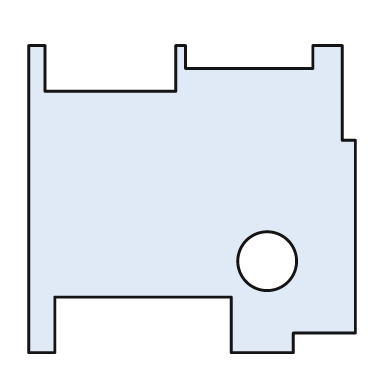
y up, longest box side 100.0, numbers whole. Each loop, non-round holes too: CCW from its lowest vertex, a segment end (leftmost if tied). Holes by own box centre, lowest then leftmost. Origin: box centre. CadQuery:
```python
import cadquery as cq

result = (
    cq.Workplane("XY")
    .moveTo(-50.0, -47.0)
    .lineTo(-42.0, -47.0)
    .lineTo(-42.0, -30.0)
    .lineTo(12.0, -30.0)
    .lineTo(12.0, -47.0)
    .lineTo(31.0, -47.0)
    .lineTo(31.0, -41.0)
    .lineTo(50.0, -41.0)
    .lineTo(50.0, 18.0)
    .lineTo(46.0, 18.0)
    .lineTo(46.0, 47.0)
    .lineTo(37.0, 47.0)
    .lineTo(37.0, 40.0)
    .lineTo(-2.0, 40.0)
    .lineTo(-2.0, 47.0)
    .lineTo(-5.0, 47.0)
    .lineTo(-5.0, 33.0)
    .lineTo(-45.0, 33.0)
    .lineTo(-45.0, 47.0)
    .lineTo(-50.0, 47.0)
    .close()
    .moveTo(23.0, -19.0)
    .circle(9.0)
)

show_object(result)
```